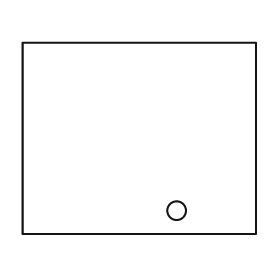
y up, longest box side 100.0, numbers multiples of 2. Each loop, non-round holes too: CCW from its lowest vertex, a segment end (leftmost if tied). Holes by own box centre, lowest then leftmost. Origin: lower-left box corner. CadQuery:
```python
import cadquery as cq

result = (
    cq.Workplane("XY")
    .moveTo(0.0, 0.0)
    .lineTo(100.0, 0.0)
    .lineTo(100.0, 82.0)
    .lineTo(0.0, 82.0)
    .close()
    .moveTo(66.0, 10.0)
    .circle(4.0)
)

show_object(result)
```